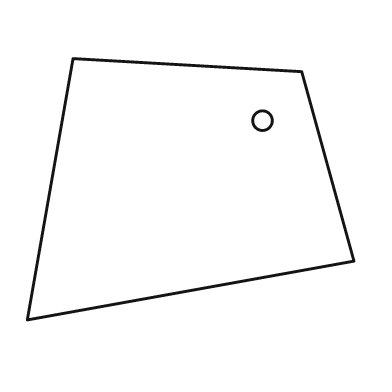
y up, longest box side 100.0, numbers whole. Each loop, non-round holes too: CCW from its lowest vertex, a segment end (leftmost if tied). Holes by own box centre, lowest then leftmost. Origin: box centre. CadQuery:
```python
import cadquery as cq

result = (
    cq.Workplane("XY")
    .moveTo(-50.0, -40.0)
    .lineTo(50.0, -22.0)
    .lineTo(34.0, 36.0)
    .lineTo(-36.0, 40.0)
    .close()
    .moveTo(22.0, 21.0)
    .circle(3.0)
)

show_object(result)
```